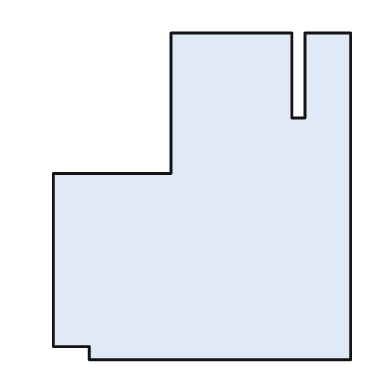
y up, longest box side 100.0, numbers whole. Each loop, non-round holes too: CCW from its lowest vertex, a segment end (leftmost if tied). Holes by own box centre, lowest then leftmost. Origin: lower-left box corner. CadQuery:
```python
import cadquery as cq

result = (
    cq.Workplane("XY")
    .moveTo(11.0, 0.0)
    .lineTo(91.0, 0.0)
    .lineTo(91.0, 100.0)
    .lineTo(77.0, 100.0)
    .lineTo(77.0, 74.0)
    .lineTo(73.0, 74.0)
    .lineTo(73.0, 100.0)
    .lineTo(36.0, 100.0)
    .lineTo(36.0, 57.0)
    .lineTo(0.0, 57.0)
    .lineTo(0.0, 4.0)
    .lineTo(11.0, 4.0)
    .close()
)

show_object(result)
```